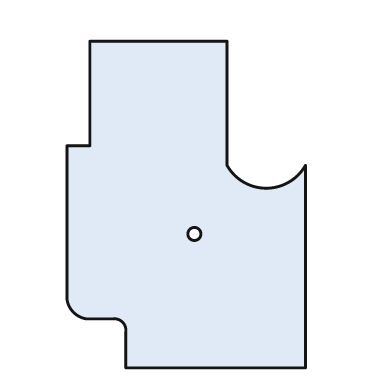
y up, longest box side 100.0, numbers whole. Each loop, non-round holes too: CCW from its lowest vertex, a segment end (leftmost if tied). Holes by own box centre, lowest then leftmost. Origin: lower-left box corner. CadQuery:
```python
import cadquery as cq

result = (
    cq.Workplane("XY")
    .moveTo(18.0, 0.0)
    .lineTo(73.0, 0.0)
    .lineTo(73.0, 62.0)
    .threePointArc((61.0, 55.0), (49.0, 62.0))
    .lineTo(49.0, 100.0)
    .lineTo(7.0, 100.0)
    .lineTo(7.0, 68.0)
    .lineTo(0.0, 68.0)
    .lineTo(0.0, 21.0)
    .threePointArc((2.0, 17.0), (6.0, 15.0))
    .lineTo(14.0, 15.0)
    .threePointArc((17.0, 14.0), (18.0, 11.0))
    .close()
    .moveTo(39.0, 41.0)
    .circle(2.0)
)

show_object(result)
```